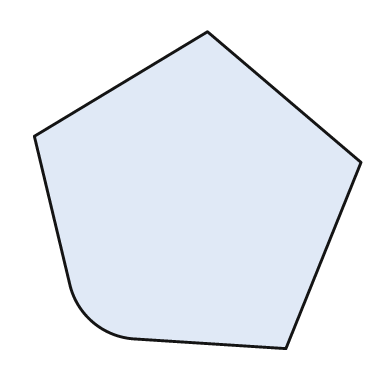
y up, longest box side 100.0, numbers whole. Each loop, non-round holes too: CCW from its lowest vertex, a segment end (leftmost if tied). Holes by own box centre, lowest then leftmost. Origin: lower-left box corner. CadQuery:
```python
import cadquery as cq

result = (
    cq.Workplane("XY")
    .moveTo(77.0, 0.0)
    .lineTo(100.0, 57.0)
    .lineTo(53.0, 97.0)
    .lineTo(0.0, 65.0)
    .lineTo(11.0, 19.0)
    .threePointArc((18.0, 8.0), (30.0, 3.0))
    .close()
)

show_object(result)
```